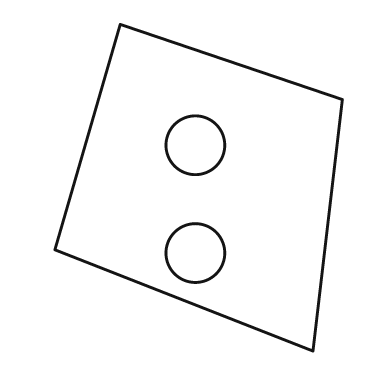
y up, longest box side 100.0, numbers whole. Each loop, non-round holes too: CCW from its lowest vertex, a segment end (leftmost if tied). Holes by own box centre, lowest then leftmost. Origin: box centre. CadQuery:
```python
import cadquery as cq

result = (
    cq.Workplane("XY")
    .moveTo(35.0, -50.0)
    .lineTo(44.0, 27.0)
    .lineTo(-24.0, 50.0)
    .lineTo(-44.0, -19.0)
    .close()
    .moveTo(-1.0, -20.0)
    .circle(9.0)
    .moveTo(-1.0, 13.0)
    .circle(9.0)
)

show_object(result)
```